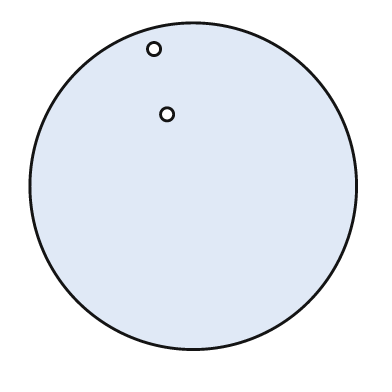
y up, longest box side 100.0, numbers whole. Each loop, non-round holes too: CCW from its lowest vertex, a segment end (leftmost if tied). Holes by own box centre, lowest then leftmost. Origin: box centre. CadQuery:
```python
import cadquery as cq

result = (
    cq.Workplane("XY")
    .moveTo(0.0, 0.0)
    .circle(50.0)
    .moveTo(-8.0, 22.0)
    .circle(2.0)
    .moveTo(-12.0, 42.0)
    .circle(2.0)
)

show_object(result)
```